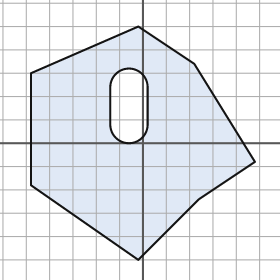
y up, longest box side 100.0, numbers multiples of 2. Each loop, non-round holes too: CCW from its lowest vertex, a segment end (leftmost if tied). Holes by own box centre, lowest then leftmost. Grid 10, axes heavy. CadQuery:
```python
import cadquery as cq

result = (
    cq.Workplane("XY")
    .moveTo(-2.0, -50.0)
    .lineTo(24.0, -24.0)
    .lineTo(48.0, -8.0)
    .lineTo(22.0, 34.0)
    .lineTo(-2.0, 50.0)
    .lineTo(-48.0, 30.0)
    .lineTo(-48.0, -18.0)
    .close()
    .moveTo(-14.0, 8.0)
    .threePointArc((-6.0, 0.0), (2.0, 8.0))
    .lineTo(2.0, 24.0)
    .threePointArc((-6.0, 32.0), (-14.0, 24.0))
    .close()
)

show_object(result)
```